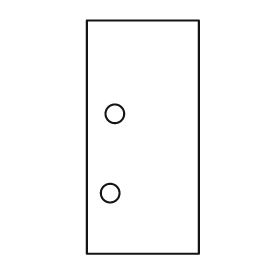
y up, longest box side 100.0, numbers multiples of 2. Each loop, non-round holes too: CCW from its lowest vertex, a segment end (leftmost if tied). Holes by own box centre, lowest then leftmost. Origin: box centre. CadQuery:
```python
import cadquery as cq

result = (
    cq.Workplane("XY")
    .moveTo(-24.0, -50.0)
    .lineTo(24.0, -50.0)
    .lineTo(24.0, 50.0)
    .lineTo(-24.0, 50.0)
    .close()
    .moveTo(-14.0, -24.0)
    .circle(4.0)
    .moveTo(-12.0, 10.0)
    .circle(4.0)
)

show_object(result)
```